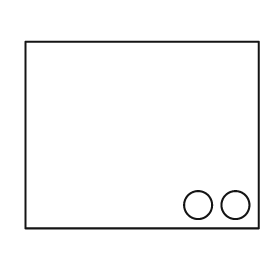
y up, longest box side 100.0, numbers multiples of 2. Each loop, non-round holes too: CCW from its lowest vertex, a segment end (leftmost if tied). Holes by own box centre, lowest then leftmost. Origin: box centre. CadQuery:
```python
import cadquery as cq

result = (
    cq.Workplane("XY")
    .moveTo(-50.0, -40.0)
    .lineTo(50.0, -40.0)
    .lineTo(50.0, 40.0)
    .lineTo(-50.0, 40.0)
    .close()
    .moveTo(24.0, -30.0)
    .circle(6.0)
    .moveTo(40.0, -30.0)
    .circle(6.0)
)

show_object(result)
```